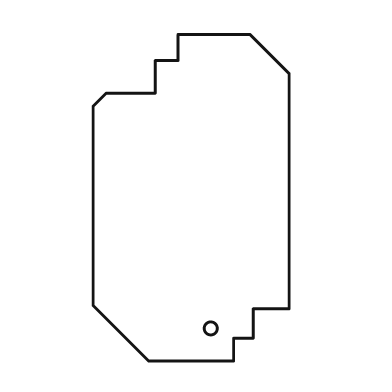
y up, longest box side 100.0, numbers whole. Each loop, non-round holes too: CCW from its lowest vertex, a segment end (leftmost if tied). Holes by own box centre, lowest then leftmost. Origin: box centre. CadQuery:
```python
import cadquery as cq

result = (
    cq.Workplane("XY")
    .moveTo(-13.0, -50.0)
    .lineTo(13.0, -50.0)
    .lineTo(13.0, -43.0)
    .lineTo(19.0, -43.0)
    .lineTo(19.0, -34.0)
    .lineTo(30.0, -34.0)
    .lineTo(30.0, 38.0)
    .lineTo(18.0, 50.0)
    .lineTo(-4.0, 50.0)
    .lineTo(-4.0, 42.0)
    .lineTo(-11.0, 42.0)
    .lineTo(-11.0, 32.0)
    .lineTo(-26.0, 32.0)
    .lineTo(-30.0, 28.0)
    .lineTo(-30.0, -33.0)
    .close()
    .moveTo(6.0, -40.0)
    .circle(2.0)
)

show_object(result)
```